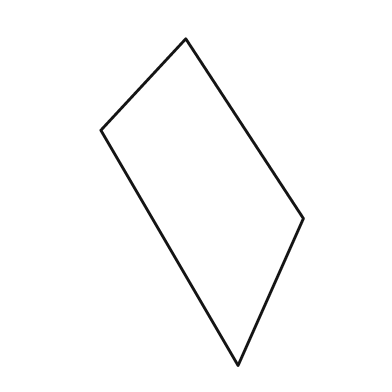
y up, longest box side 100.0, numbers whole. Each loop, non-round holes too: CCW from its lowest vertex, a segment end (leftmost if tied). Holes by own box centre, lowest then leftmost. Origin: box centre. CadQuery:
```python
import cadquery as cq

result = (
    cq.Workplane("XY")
    .moveTo(11.0, -50.0)
    .lineTo(31.0, -5.0)
    .lineTo(-5.0, 50.0)
    .lineTo(-31.0, 22.0)
    .close()
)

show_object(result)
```